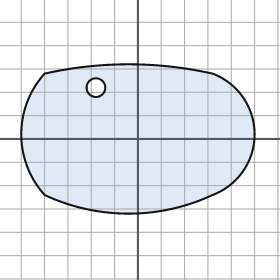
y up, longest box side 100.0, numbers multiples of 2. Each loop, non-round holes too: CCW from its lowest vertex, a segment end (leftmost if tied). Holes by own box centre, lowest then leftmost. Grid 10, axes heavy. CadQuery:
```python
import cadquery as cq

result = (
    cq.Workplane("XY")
    .moveTo(-40.0, -24.0)
    .threePointArc((-4.0, -32.0), (32.0, -24.0))
    .threePointArc((50.0, 2.0), (32.0, 28.0))
    .threePointArc((-4.0, 32.0), (-40.0, 28.0))
    .threePointArc((-50.0, 2.0), (-40.0, -24.0))
    .close()
    .moveTo(-18.0, 22.0)
    .circle(4.0)
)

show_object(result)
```